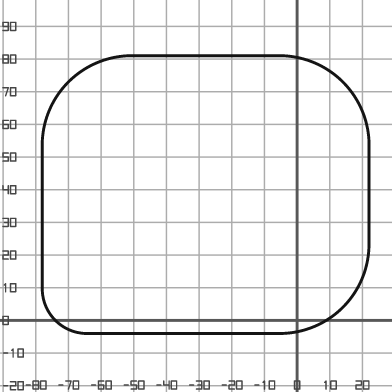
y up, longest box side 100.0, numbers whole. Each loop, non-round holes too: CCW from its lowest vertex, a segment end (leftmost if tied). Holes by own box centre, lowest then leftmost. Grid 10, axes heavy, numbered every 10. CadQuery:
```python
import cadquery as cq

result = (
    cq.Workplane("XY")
    .moveTo(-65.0, -4.0)
    .lineTo(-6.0, -4.0)
    .threePointArc((14.0, 4.0), (22.0, 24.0))
    .lineTo(22.0, 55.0)
    .threePointArc((14.0, 73.0), (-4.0, 81.0))
    .lineTo(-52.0, 81.0)
    .threePointArc((-70.0, 73.0), (-78.0, 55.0))
    .lineTo(-78.0, 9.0)
    .threePointArc((-74.0, 0.0), (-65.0, -4.0))
    .close()
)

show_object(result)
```